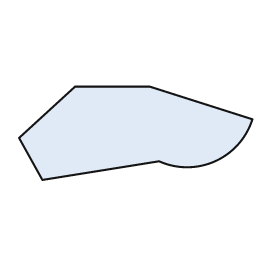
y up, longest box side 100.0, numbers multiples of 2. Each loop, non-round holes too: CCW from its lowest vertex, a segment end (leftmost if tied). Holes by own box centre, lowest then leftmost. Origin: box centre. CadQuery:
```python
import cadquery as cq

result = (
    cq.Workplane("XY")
    .moveTo(-40.0, -20.0)
    .lineTo(10.0, -12.0)
    .threePointArc((34.0, -12.0), (50.0, 6.0))
    .lineTo(6.0, 20.0)
    .lineTo(-26.0, 20.0)
    .lineTo(-50.0, -2.0)
    .close()
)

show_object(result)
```